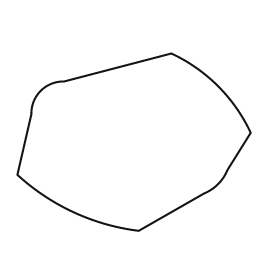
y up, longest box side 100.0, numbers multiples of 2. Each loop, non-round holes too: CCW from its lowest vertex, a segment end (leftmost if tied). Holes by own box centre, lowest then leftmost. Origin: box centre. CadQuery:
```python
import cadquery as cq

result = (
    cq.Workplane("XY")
    .moveTo(2.0, -38.0)
    .lineTo(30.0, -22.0)
    .threePointArc((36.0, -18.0), (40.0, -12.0))
    .lineTo(50.0, 4.0)
    .threePointArc((36.0, 24.0), (16.0, 38.0))
    .lineTo(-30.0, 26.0)
    .threePointArc((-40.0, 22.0), (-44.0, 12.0))
    .lineTo(-50.0, -14.0)
    .threePointArc((-26.0, -30.0), (2.0, -38.0))
    .close()
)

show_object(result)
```